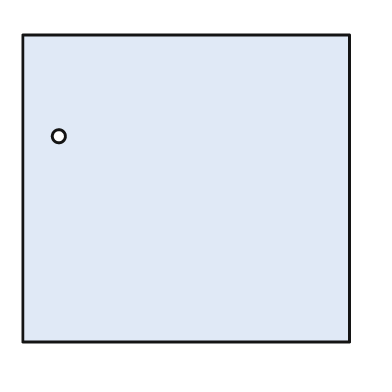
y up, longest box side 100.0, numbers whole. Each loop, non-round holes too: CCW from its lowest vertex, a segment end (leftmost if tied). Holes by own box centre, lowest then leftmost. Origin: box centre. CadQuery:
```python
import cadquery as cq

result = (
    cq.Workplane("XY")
    .moveTo(-50.0, -47.0)
    .lineTo(50.0, -47.0)
    .lineTo(50.0, 47.0)
    .lineTo(-50.0, 47.0)
    .close()
    .moveTo(-39.0, 16.0)
    .circle(2.0)
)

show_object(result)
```